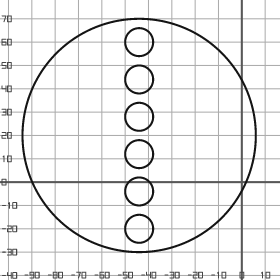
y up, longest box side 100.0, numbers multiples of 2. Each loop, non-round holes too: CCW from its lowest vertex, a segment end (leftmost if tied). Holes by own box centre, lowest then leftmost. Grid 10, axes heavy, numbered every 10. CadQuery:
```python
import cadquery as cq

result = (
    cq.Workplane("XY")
    .moveTo(-44.0, 20.0)
    .circle(50.0)
    .moveTo(-44.0, -20.0)
    .circle(6.0)
    .moveTo(-44.0, -4.0)
    .circle(6.0)
    .moveTo(-44.0, 12.0)
    .circle(6.0)
    .moveTo(-44.0, 28.0)
    .circle(6.0)
    .moveTo(-44.0, 44.0)
    .circle(6.0)
    .moveTo(-44.0, 60.0)
    .circle(6.0)
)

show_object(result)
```